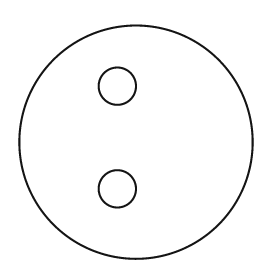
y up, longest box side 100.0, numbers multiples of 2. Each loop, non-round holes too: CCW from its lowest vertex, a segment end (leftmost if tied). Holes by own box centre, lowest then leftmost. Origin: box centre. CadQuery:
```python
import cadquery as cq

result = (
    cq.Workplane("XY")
    .moveTo(0.0, 0.0)
    .circle(50.0)
    .moveTo(-8.0, -20.0)
    .circle(8.0)
    .moveTo(-8.0, 24.0)
    .circle(8.0)
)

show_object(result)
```